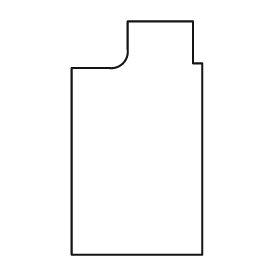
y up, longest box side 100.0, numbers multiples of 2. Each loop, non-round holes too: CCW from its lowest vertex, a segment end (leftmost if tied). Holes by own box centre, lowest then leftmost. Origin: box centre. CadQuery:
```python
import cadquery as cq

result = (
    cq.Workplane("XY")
    .moveTo(-28.0, -50.0)
    .lineTo(28.0, -50.0)
    .lineTo(28.0, 32.0)
    .lineTo(24.0, 32.0)
    .lineTo(24.0, 50.0)
    .lineTo(-4.0, 50.0)
    .lineTo(-4.0, 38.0)
    .threePointArc((-6.0, 32.0), (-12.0, 30.0))
    .lineTo(-28.0, 30.0)
    .close()
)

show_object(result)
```